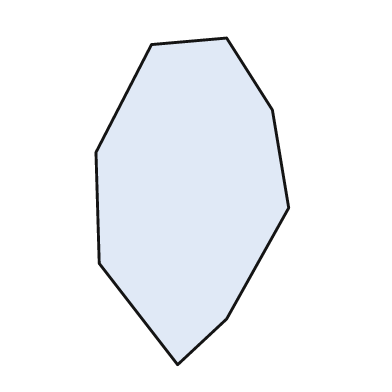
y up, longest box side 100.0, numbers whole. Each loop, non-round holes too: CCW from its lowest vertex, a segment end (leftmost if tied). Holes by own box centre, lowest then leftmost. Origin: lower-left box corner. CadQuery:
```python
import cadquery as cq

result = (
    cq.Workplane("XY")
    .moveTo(25.0, 0.0)
    .lineTo(40.0, 14.0)
    .lineTo(59.0, 48.0)
    .lineTo(54.0, 78.0)
    .lineTo(40.0, 100.0)
    .lineTo(17.0, 98.0)
    .lineTo(0.0, 65.0)
    .lineTo(1.0, 31.0)
    .close()
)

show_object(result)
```